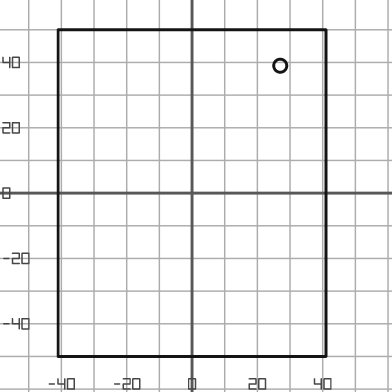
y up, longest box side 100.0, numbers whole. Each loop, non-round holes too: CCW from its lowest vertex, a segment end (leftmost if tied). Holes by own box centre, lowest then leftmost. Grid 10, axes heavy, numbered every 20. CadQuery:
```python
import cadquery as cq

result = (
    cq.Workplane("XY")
    .moveTo(-41.0, -50.0)
    .lineTo(41.0, -50.0)
    .lineTo(41.0, 50.0)
    .lineTo(-41.0, 50.0)
    .close()
    .moveTo(27.0, 39.0)
    .circle(2.0)
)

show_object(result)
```